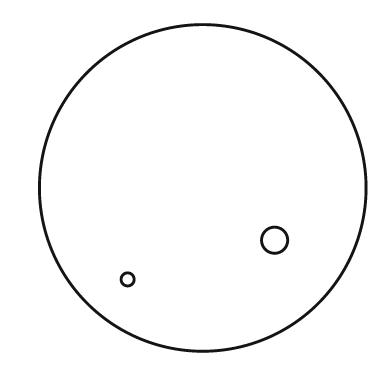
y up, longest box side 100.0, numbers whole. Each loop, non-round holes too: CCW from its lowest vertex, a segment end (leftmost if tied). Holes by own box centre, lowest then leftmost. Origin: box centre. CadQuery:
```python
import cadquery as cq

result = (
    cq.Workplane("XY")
    .moveTo(0.0, 0.0)
    .circle(50.0)
    .moveTo(-23.0, -28.0)
    .circle(2.0)
    .moveTo(22.0, -16.0)
    .circle(4.0)
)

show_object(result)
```